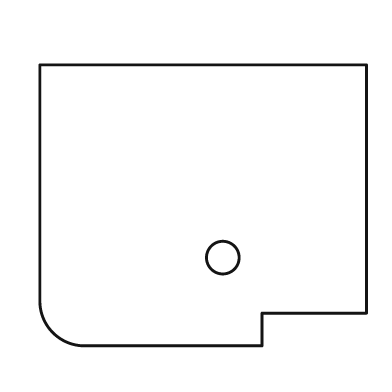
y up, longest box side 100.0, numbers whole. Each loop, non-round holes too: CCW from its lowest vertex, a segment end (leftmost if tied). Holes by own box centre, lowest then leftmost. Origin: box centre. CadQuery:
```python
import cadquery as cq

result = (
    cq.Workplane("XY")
    .moveTo(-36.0, -43.0)
    .lineTo(18.0, -43.0)
    .lineTo(18.0, -33.0)
    .lineTo(50.0, -33.0)
    .lineTo(50.0, 43.0)
    .lineTo(-50.0, 43.0)
    .lineTo(-50.0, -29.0)
    .threePointArc((-46.0, -39.0), (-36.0, -43.0))
    .close()
    .moveTo(6.0, -16.0)
    .circle(5.0)
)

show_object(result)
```